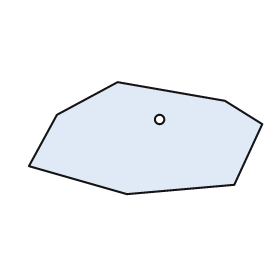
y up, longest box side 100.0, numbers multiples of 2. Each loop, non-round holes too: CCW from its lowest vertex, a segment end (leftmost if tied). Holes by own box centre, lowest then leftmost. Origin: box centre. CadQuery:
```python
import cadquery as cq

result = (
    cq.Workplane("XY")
    .moveTo(-8.0, -24.0)
    .lineTo(38.0, -20.0)
    .lineTo(50.0, 6.0)
    .lineTo(34.0, 16.0)
    .lineTo(-12.0, 24.0)
    .lineTo(-38.0, 10.0)
    .lineTo(-50.0, -12.0)
    .close()
    .moveTo(6.0, 8.0)
    .circle(2.0)
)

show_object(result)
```